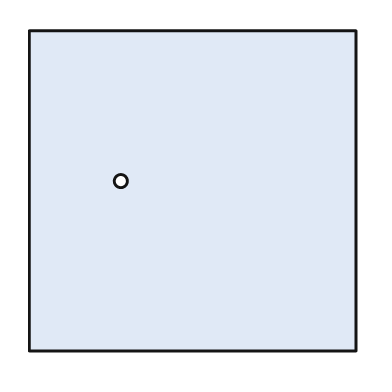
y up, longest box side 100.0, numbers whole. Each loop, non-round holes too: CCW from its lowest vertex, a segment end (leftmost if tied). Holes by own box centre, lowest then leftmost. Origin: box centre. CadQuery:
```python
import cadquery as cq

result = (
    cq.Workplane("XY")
    .moveTo(-50.0, -49.0)
    .lineTo(50.0, -49.0)
    .lineTo(50.0, 49.0)
    .lineTo(-50.0, 49.0)
    .close()
    .moveTo(-22.0, 3.0)
    .circle(2.0)
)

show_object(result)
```